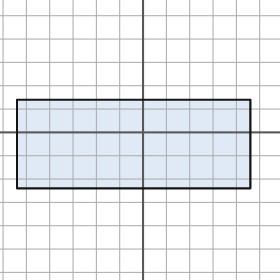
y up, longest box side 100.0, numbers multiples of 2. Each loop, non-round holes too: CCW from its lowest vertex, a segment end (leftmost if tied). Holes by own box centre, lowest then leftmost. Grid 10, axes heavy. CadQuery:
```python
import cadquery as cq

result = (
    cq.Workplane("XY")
    .moveTo(-54.0, -24.0)
    .lineTo(46.0, -24.0)
    .lineTo(46.0, 14.0)
    .lineTo(-54.0, 14.0)
    .close()
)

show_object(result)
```